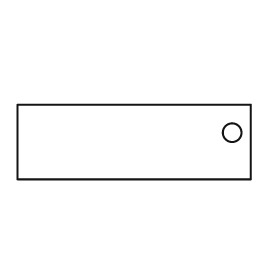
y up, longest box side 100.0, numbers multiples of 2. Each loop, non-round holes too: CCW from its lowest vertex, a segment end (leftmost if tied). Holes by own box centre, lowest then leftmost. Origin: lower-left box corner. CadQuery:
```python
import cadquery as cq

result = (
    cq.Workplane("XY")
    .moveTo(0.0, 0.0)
    .lineTo(100.0, 0.0)
    .lineTo(100.0, 32.0)
    .lineTo(0.0, 32.0)
    .close()
    .moveTo(92.0, 20.0)
    .circle(4.0)
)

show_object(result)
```